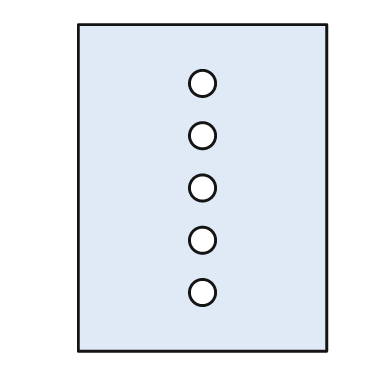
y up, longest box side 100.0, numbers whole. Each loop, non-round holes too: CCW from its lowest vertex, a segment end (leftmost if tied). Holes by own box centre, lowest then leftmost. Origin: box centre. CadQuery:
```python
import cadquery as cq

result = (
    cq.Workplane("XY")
    .moveTo(-38.0, -50.0)
    .lineTo(38.0, -50.0)
    .lineTo(38.0, 50.0)
    .lineTo(-38.0, 50.0)
    .close()
    .moveTo(0.0, -32.0)
    .circle(4.0)
    .moveTo(0.0, -16.0)
    .circle(4.0)
    .moveTo(0.0, 0.0)
    .circle(4.0)
    .moveTo(0.0, 16.0)
    .circle(4.0)
    .moveTo(0.0, 32.0)
    .circle(4.0)
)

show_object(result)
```